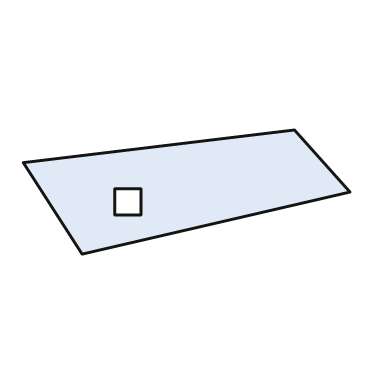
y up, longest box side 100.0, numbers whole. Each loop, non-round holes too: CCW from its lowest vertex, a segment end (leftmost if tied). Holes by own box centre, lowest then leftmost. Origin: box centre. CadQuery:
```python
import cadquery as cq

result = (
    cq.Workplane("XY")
    .moveTo(-32.0, -19.0)
    .lineTo(50.0, 0.0)
    .lineTo(33.0, 19.0)
    .lineTo(-50.0, 9.0)
    .close()
    .moveTo(-22.0, -7.0)
    .lineTo(-14.0, -7.0)
    .lineTo(-14.0, 1.0)
    .lineTo(-22.0, 1.0)
    .close()
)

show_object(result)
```